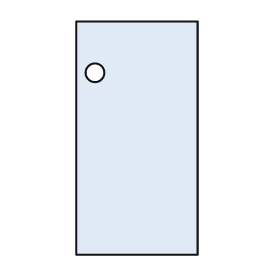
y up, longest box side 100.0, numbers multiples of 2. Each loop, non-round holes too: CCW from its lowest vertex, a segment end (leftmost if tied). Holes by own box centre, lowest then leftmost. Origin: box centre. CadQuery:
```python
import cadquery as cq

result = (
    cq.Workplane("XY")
    .moveTo(-26.0, -50.0)
    .lineTo(26.0, -50.0)
    .lineTo(26.0, 50.0)
    .lineTo(-26.0, 50.0)
    .close()
    .moveTo(-18.0, 28.0)
    .circle(4.0)
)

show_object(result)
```